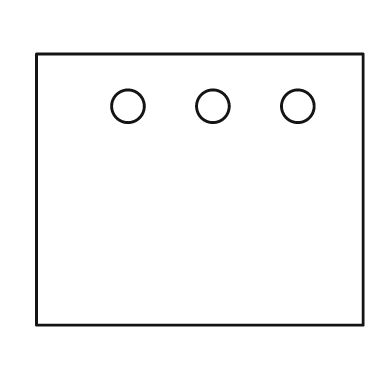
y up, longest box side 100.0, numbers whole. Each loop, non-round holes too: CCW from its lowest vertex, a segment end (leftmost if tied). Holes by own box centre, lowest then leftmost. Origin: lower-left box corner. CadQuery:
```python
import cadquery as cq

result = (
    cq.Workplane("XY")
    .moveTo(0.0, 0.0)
    .lineTo(100.0, 0.0)
    .lineTo(100.0, 83.0)
    .lineTo(0.0, 83.0)
    .close()
    .moveTo(28.0, 67.0)
    .circle(5.0)
    .moveTo(54.0, 67.0)
    .circle(5.0)
    .moveTo(80.0, 67.0)
    .circle(5.0)
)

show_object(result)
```